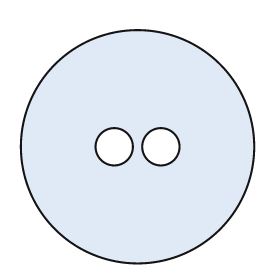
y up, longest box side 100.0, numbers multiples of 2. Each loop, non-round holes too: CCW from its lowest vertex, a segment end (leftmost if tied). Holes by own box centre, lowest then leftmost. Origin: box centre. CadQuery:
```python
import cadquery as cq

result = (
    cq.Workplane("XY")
    .moveTo(0.0, 0.0)
    .circle(50.0)
    .moveTo(-10.0, 0.0)
    .circle(8.0)
    .moveTo(10.0, 0.0)
    .circle(8.0)
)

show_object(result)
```